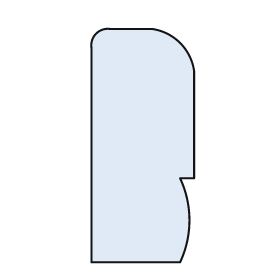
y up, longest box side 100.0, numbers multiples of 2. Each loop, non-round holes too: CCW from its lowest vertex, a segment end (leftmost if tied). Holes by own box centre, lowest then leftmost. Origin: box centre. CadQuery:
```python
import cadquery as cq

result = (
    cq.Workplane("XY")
    .moveTo(-22.0, -50.0)
    .lineTo(16.0, -50.0)
    .threePointArc((20.0, -32.0), (16.0, -14.0))
    .lineTo(22.0, -14.0)
    .lineTo(22.0, 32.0)
    .threePointArc((16.0, 44.0), (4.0, 50.0))
    .lineTo(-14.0, 50.0)
    .threePointArc((-20.0, 48.0), (-22.0, 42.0))
    .close()
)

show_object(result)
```